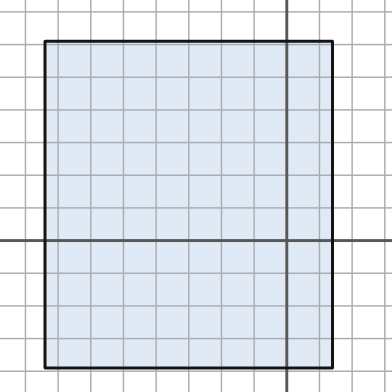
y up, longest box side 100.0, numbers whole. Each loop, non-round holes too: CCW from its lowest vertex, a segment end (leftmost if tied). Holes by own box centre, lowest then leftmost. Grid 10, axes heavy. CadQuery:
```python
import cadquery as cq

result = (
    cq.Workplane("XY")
    .moveTo(-74.0, -39.0)
    .lineTo(14.0, -39.0)
    .lineTo(14.0, 61.0)
    .lineTo(-74.0, 61.0)
    .close()
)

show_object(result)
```